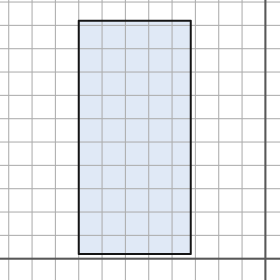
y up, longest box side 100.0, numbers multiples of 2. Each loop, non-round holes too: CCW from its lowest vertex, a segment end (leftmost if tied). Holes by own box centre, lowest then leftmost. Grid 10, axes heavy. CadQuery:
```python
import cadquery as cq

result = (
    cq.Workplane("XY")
    .moveTo(-80.0, 2.0)
    .lineTo(-32.0, 2.0)
    .lineTo(-32.0, 102.0)
    .lineTo(-80.0, 102.0)
    .close()
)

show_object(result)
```